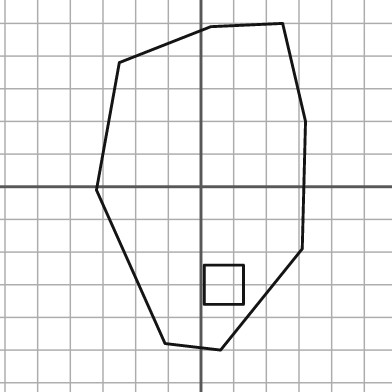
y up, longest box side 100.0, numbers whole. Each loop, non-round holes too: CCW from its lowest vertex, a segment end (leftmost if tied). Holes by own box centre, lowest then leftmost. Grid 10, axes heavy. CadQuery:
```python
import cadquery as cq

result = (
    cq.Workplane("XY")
    .moveTo(6.0, -50.0)
    .lineTo(31.0, -19.0)
    .lineTo(32.0, 20.0)
    .lineTo(25.0, 50.0)
    .lineTo(3.0, 49.0)
    .lineTo(-25.0, 38.0)
    .lineTo(-32.0, -1.0)
    .lineTo(-11.0, -48.0)
    .close()
    .moveTo(1.0, -36.0)
    .lineTo(13.0, -36.0)
    .lineTo(13.0, -24.0)
    .lineTo(1.0, -24.0)
    .close()
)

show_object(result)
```